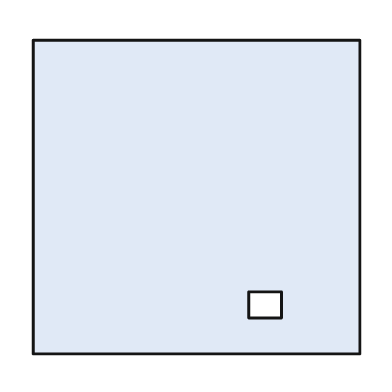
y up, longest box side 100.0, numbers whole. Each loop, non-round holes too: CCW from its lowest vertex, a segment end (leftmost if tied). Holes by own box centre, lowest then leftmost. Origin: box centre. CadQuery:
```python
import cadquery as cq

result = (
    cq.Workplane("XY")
    .moveTo(-50.0, -48.0)
    .lineTo(50.0, -48.0)
    .lineTo(50.0, 48.0)
    .lineTo(-50.0, 48.0)
    .close()
    .moveTo(16.0, -37.0)
    .lineTo(26.0, -37.0)
    .lineTo(26.0, -29.0)
    .lineTo(16.0, -29.0)
    .close()
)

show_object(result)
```